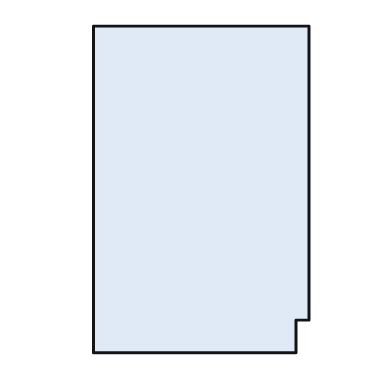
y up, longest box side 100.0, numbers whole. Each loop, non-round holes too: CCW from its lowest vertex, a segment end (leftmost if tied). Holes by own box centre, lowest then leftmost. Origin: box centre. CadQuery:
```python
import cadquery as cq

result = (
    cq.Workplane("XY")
    .moveTo(-33.0, -50.0)
    .lineTo(29.0, -50.0)
    .lineTo(29.0, -40.0)
    .lineTo(33.0, -40.0)
    .lineTo(33.0, 50.0)
    .lineTo(-33.0, 50.0)
    .close()
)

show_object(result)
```